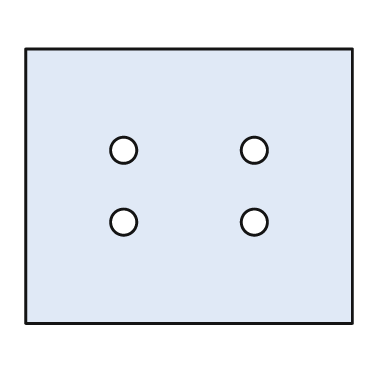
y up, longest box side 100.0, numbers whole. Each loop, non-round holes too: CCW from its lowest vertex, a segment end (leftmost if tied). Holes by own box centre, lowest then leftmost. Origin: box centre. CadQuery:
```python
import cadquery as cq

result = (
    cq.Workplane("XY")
    .moveTo(-50.0, -42.0)
    .lineTo(50.0, -42.0)
    .lineTo(50.0, 42.0)
    .lineTo(-50.0, 42.0)
    .close()
    .moveTo(-20.0, -11.0)
    .circle(4.0)
    .moveTo(20.0, -11.0)
    .circle(4.0)
    .moveTo(-20.0, 11.0)
    .circle(4.0)
    .moveTo(20.0, 11.0)
    .circle(4.0)
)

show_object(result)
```